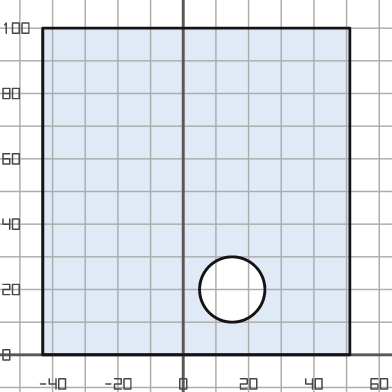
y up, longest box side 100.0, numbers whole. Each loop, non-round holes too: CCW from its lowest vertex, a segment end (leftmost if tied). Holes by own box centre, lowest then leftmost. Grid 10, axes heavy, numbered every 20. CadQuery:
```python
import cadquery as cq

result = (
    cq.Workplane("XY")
    .moveTo(-43.0, 0.0)
    .lineTo(51.0, 0.0)
    .lineTo(51.0, 100.0)
    .lineTo(-43.0, 100.0)
    .close()
    .moveTo(15.0, 20.0)
    .circle(10.0)
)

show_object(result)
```